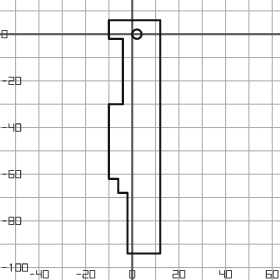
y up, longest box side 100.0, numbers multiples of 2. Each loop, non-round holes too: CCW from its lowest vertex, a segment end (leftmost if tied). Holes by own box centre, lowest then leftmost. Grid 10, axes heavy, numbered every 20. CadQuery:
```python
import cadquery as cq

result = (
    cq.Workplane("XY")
    .moveTo(-2.0, -94.0)
    .lineTo(12.0, -94.0)
    .lineTo(12.0, 6.0)
    .lineTo(-10.0, 6.0)
    .lineTo(-10.0, -2.0)
    .lineTo(-4.0, -2.0)
    .lineTo(-4.0, -30.0)
    .lineTo(-10.0, -30.0)
    .lineTo(-10.0, -62.0)
    .lineTo(-6.0, -62.0)
    .lineTo(-6.0, -68.0)
    .lineTo(-2.0, -68.0)
    .close()
    .moveTo(2.0, 0.0)
    .circle(2.0)
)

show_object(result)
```